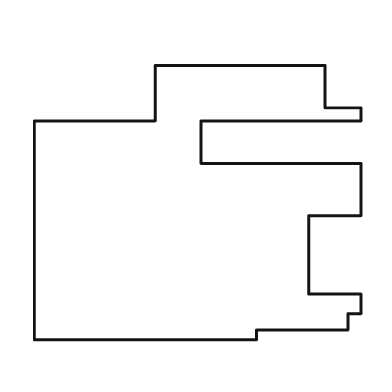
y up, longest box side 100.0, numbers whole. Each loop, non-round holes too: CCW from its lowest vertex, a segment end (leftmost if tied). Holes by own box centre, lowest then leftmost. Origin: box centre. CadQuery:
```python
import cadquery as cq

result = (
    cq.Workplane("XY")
    .moveTo(-50.0, -42.0)
    .lineTo(18.0, -42.0)
    .lineTo(18.0, -39.0)
    .lineTo(46.0, -39.0)
    .lineTo(46.0, -34.0)
    .lineTo(50.0, -34.0)
    .lineTo(50.0, -28.0)
    .lineTo(34.0, -28.0)
    .lineTo(34.0, -4.0)
    .lineTo(50.0, -4.0)
    .lineTo(50.0, 12.0)
    .lineTo(1.0, 12.0)
    .lineTo(1.0, 25.0)
    .lineTo(50.0, 25.0)
    .lineTo(50.0, 29.0)
    .lineTo(39.0, 29.0)
    .lineTo(39.0, 42.0)
    .lineTo(-13.0, 42.0)
    .lineTo(-13.0, 25.0)
    .lineTo(-50.0, 25.0)
    .close()
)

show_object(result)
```